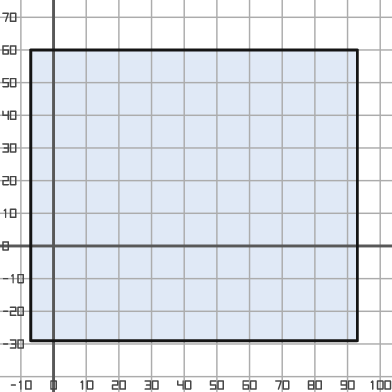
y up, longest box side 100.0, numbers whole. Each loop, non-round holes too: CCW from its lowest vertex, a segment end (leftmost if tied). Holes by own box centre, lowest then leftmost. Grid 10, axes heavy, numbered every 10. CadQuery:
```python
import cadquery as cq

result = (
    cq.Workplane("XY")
    .moveTo(-7.0, -29.0)
    .lineTo(93.0, -29.0)
    .lineTo(93.0, 60.0)
    .lineTo(-7.0, 60.0)
    .close()
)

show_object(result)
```